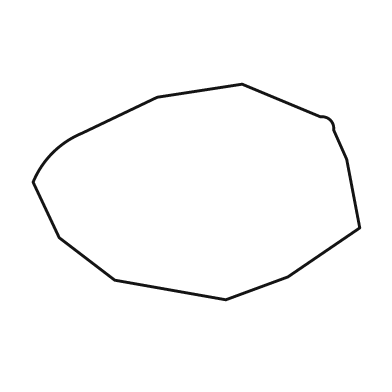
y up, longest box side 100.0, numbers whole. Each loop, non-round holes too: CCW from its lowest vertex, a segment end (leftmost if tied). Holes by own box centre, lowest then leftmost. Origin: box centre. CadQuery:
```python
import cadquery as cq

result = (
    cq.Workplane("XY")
    .moveTo(9.0, -33.0)
    .lineTo(28.0, -26.0)
    .lineTo(50.0, -11.0)
    .lineTo(46.0, 10.0)
    .lineTo(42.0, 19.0)
    .threePointArc((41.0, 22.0), (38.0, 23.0))
    .lineTo(14.0, 33.0)
    .lineTo(-12.0, 29.0)
    .lineTo(-35.0, 18.0)
    .threePointArc((-44.0, 12.0), (-50.0, 3.0))
    .lineTo(-42.0, -14.0)
    .lineTo(-25.0, -27.0)
    .close()
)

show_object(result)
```